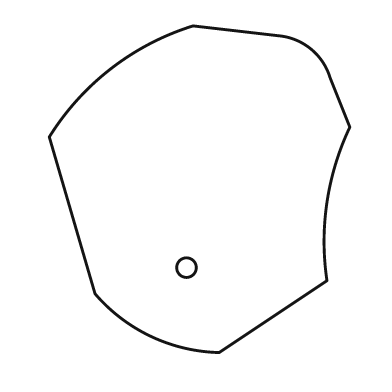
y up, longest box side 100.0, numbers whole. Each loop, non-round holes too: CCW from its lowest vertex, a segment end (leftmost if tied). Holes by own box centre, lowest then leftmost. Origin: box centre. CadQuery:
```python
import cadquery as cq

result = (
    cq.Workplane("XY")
    .moveTo(6.0, -50.0)
    .lineTo(39.0, -28.0)
    .threePointArc((39.0, -4.0), (46.0, 19.0))
    .lineTo(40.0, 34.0)
    .threePointArc((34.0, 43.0), (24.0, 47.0))
    .lineTo(-2.0, 50.0)
    .threePointArc((-27.0, 37.0), (-46.0, 16.0))
    .lineTo(-32.0, -32.0)
    .threePointArc((-15.0, -45.0), (6.0, -50.0))
    .close()
    .moveTo(-4.0, -24.0)
    .circle(3.0)
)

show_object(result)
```